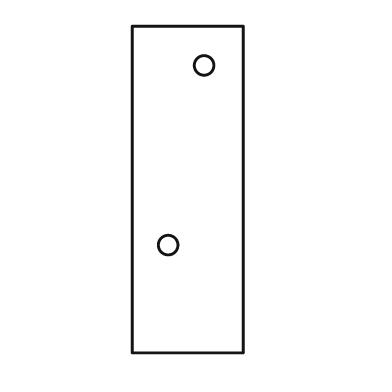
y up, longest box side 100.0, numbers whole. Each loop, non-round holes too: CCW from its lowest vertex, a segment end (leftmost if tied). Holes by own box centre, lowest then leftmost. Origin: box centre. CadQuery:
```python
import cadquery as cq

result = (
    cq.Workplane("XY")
    .moveTo(-17.0, -50.0)
    .lineTo(17.0, -50.0)
    .lineTo(17.0, 50.0)
    .lineTo(-17.0, 50.0)
    .close()
    .moveTo(-6.0, -17.0)
    .circle(3.0)
    .moveTo(5.0, 38.0)
    .circle(3.0)
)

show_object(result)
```